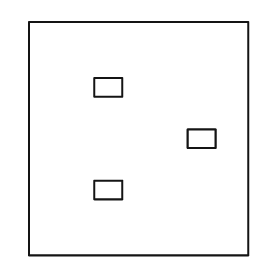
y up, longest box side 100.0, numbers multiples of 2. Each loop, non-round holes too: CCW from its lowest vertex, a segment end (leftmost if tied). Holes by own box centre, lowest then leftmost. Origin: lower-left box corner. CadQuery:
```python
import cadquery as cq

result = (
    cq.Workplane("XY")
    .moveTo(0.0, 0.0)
    .lineTo(94.0, 0.0)
    .lineTo(94.0, 100.0)
    .lineTo(0.0, 100.0)
    .close()
    .moveTo(28.0, 24.0)
    .lineTo(40.0, 24.0)
    .lineTo(40.0, 32.0)
    .lineTo(28.0, 32.0)
    .close()
    .moveTo(68.0, 46.0)
    .lineTo(80.0, 46.0)
    .lineTo(80.0, 54.0)
    .lineTo(68.0, 54.0)
    .close()
    .moveTo(28.0, 68.0)
    .lineTo(40.0, 68.0)
    .lineTo(40.0, 76.0)
    .lineTo(28.0, 76.0)
    .close()
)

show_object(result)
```